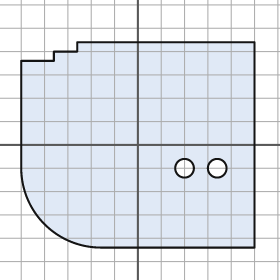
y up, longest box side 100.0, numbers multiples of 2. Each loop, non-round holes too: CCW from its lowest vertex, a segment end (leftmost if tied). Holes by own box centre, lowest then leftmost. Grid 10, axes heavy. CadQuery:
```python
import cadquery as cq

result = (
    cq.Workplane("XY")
    .moveTo(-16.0, -44.0)
    .lineTo(50.0, -44.0)
    .lineTo(50.0, 44.0)
    .lineTo(-26.0, 44.0)
    .lineTo(-26.0, 40.0)
    .lineTo(-36.0, 40.0)
    .lineTo(-36.0, 36.0)
    .lineTo(-50.0, 36.0)
    .lineTo(-50.0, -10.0)
    .threePointArc((-40.0, -34.0), (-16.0, -44.0))
    .close()
    .moveTo(20.0, -10.0)
    .circle(4.0)
    .moveTo(34.0, -10.0)
    .circle(4.0)
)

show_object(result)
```